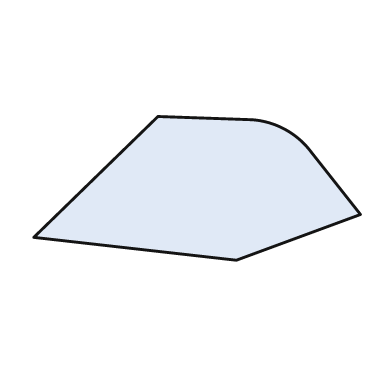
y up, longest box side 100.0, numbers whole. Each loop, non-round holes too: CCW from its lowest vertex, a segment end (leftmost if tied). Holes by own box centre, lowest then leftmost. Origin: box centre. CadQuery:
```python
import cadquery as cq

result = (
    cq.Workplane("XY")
    .moveTo(12.0, -22.0)
    .lineTo(50.0, -8.0)
    .lineTo(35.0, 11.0)
    .threePointArc((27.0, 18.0), (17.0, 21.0))
    .lineTo(-12.0, 22.0)
    .lineTo(-50.0, -15.0)
    .close()
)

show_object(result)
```